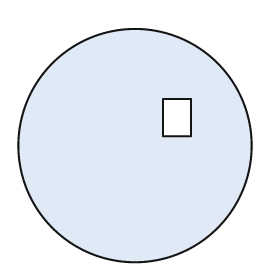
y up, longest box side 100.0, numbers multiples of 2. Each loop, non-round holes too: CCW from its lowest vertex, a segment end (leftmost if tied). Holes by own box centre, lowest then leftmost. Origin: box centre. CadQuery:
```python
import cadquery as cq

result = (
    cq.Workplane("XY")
    .moveTo(0.0, 0.0)
    .circle(50.0)
    .moveTo(12.0, 4.0)
    .lineTo(24.0, 4.0)
    .lineTo(24.0, 20.0)
    .lineTo(12.0, 20.0)
    .close()
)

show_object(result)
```